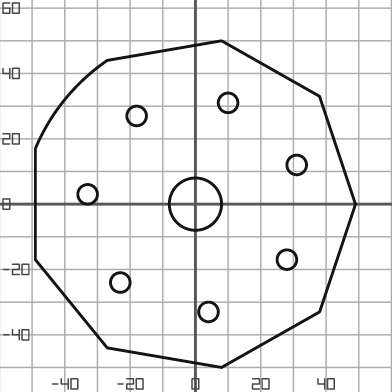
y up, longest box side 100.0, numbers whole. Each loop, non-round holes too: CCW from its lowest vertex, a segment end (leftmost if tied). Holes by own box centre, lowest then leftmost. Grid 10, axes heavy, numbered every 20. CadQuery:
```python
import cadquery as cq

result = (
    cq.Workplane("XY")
    .moveTo(8.0, -50.0)
    .lineTo(38.0, -33.0)
    .lineTo(49.0, 0.0)
    .lineTo(38.0, 33.0)
    .lineTo(8.0, 50.0)
    .lineTo(-27.0, 44.0)
    .threePointArc((-40.0, 32.0), (-49.0, 17.0))
    .lineTo(-49.0, -17.0)
    .lineTo(-27.0, -44.0)
    .close()
    .moveTo(4.0, -33.0)
    .circle(3.0)
    .moveTo(-23.0, -24.0)
    .circle(3.0)
    .moveTo(28.0, -17.0)
    .circle(3.0)
    .moveTo(0.0, 0.0)
    .circle(8.0)
    .moveTo(-33.0, 3.0)
    .circle(3.0)
    .moveTo(31.0, 12.0)
    .circle(3.0)
    .moveTo(-18.0, 27.0)
    .circle(3.0)
    .moveTo(10.0, 31.0)
    .circle(3.0)
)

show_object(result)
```